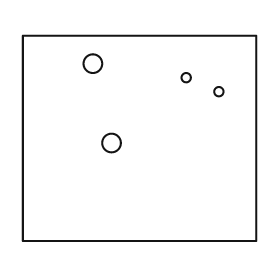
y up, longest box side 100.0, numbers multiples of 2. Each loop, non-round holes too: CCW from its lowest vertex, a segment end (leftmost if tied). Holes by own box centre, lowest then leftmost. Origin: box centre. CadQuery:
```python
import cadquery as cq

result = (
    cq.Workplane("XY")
    .moveTo(-50.0, -44.0)
    .lineTo(50.0, -44.0)
    .lineTo(50.0, 44.0)
    .lineTo(-50.0, 44.0)
    .close()
    .moveTo(-12.0, -2.0)
    .circle(4.0)
    .moveTo(34.0, 20.0)
    .circle(2.0)
    .moveTo(20.0, 26.0)
    .circle(2.0)
    .moveTo(-20.0, 32.0)
    .circle(4.0)
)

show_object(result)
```